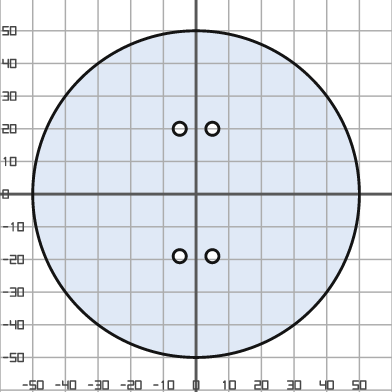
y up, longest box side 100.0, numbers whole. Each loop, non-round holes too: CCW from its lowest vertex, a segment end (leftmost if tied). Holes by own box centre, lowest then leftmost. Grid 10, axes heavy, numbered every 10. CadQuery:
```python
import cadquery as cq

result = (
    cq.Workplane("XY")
    .moveTo(0.0, 0.0)
    .circle(50.0)
    .moveTo(-5.0, -19.0)
    .circle(2.0)
    .moveTo(5.0, -19.0)
    .circle(2.0)
    .moveTo(-5.0, 20.0)
    .circle(2.0)
    .moveTo(5.0, 20.0)
    .circle(2.0)
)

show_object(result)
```